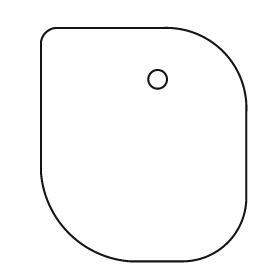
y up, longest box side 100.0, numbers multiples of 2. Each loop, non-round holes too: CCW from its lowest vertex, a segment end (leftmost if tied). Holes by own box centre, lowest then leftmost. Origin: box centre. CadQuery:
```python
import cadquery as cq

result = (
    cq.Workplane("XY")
    .moveTo(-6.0, -50.0)
    .lineTo(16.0, -50.0)
    .threePointArc((36.0, -42.0), (44.0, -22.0))
    .lineTo(44.0, 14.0)
    .threePointArc((34.0, 40.0), (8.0, 50.0))
    .lineTo(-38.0, 50.0)
    .threePointArc((-42.0, 48.0), (-44.0, 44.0))
    .lineTo(-44.0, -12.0)
    .threePointArc((-32.0, -38.0), (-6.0, -50.0))
    .close()
    .moveTo(6.0, 28.0)
    .circle(4.0)
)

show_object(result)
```